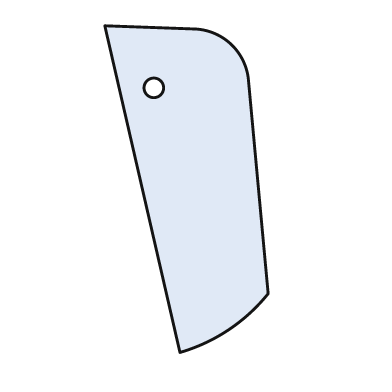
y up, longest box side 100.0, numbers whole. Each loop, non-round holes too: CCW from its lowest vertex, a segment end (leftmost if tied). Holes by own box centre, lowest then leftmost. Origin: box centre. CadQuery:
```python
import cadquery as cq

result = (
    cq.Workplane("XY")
    .moveTo(-2.0, -50.0)
    .threePointArc((13.0, -43.0), (25.0, -32.0))
    .lineTo(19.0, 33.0)
    .threePointArc((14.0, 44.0), (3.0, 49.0))
    .lineTo(-25.0, 50.0)
    .close()
    .moveTo(-10.0, 31.0)
    .circle(3.0)
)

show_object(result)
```